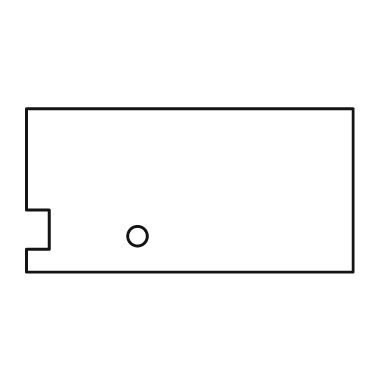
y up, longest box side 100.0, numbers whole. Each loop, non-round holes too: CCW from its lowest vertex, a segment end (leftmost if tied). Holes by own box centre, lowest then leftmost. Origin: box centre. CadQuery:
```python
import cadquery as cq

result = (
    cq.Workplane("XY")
    .moveTo(-50.0, -25.0)
    .lineTo(50.0, -25.0)
    .lineTo(50.0, 25.0)
    .lineTo(-50.0, 25.0)
    .lineTo(-50.0, -6.0)
    .lineTo(-43.0, -6.0)
    .lineTo(-43.0, -18.0)
    .lineTo(-50.0, -18.0)
    .close()
    .moveTo(-16.0, -14.0)
    .circle(3.0)
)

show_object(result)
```